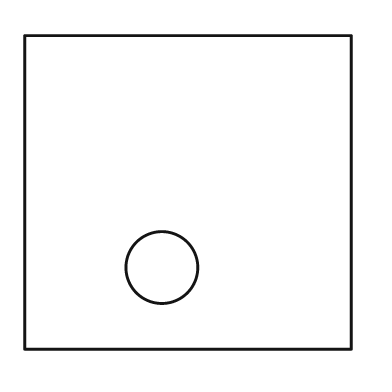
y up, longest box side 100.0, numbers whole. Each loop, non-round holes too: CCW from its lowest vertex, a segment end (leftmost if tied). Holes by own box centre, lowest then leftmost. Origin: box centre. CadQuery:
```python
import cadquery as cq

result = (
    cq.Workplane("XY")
    .moveTo(-50.0, -48.0)
    .lineTo(50.0, -48.0)
    .lineTo(50.0, 48.0)
    .lineTo(-50.0, 48.0)
    .close()
    .moveTo(-8.0, -23.0)
    .circle(11.0)
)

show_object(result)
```